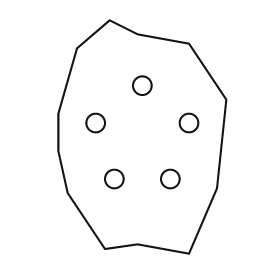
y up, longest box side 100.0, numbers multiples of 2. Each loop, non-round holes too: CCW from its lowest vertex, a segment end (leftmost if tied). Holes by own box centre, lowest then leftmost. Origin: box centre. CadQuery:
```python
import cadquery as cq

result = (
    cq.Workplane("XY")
    .moveTo(20.0, -50.0)
    .lineTo(32.0, -22.0)
    .lineTo(36.0, 16.0)
    .lineTo(20.0, 40.0)
    .lineTo(-2.0, 44.0)
    .lineTo(-14.0, 50.0)
    .lineTo(-28.0, 38.0)
    .lineTo(-36.0, 10.0)
    .lineTo(-36.0, -6.0)
    .lineTo(-32.0, -24.0)
    .lineTo(-16.0, -48.0)
    .lineTo(-2.0, -46.0)
    .close()
    .moveTo(-12.0, -18.0)
    .circle(4.0)
    .moveTo(12.0, -18.0)
    .circle(4.0)
    .moveTo(-20.0, 6.0)
    .circle(4.0)
    .moveTo(20.0, 6.0)
    .circle(4.0)
    .moveTo(0.0, 22.0)
    .circle(4.0)
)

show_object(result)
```